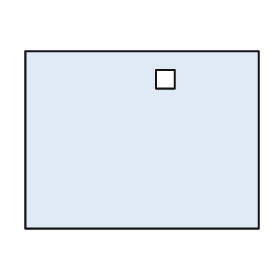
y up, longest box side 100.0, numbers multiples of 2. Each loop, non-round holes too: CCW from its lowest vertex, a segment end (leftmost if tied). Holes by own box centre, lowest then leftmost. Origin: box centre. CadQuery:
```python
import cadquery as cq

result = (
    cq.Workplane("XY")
    .moveTo(-50.0, -38.0)
    .lineTo(50.0, -38.0)
    .lineTo(50.0, 38.0)
    .lineTo(-50.0, 38.0)
    .close()
    .moveTo(6.0, 22.0)
    .lineTo(14.0, 22.0)
    .lineTo(14.0, 30.0)
    .lineTo(6.0, 30.0)
    .close()
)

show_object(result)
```